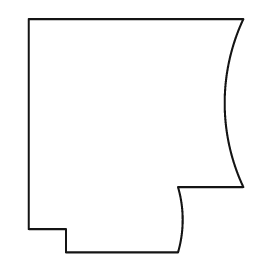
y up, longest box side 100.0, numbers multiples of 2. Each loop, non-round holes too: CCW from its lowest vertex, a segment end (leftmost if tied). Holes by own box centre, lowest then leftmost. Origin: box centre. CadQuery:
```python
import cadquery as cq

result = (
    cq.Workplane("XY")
    .moveTo(-30.0, -50.0)
    .lineTo(18.0, -50.0)
    .threePointArc((20.0, -36.0), (18.0, -22.0))
    .lineTo(46.0, -22.0)
    .threePointArc((38.0, 14.0), (46.0, 50.0))
    .lineTo(-46.0, 50.0)
    .lineTo(-46.0, -40.0)
    .lineTo(-30.0, -40.0)
    .close()
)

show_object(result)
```